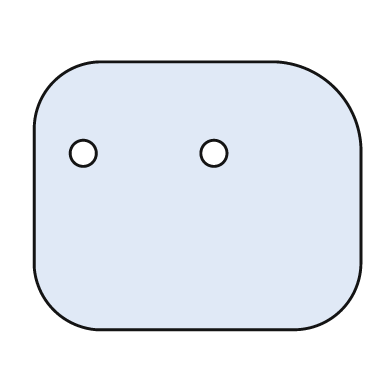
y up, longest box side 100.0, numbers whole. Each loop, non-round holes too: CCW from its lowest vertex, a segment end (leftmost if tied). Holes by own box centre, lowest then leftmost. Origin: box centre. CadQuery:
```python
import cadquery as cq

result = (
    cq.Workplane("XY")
    .moveTo(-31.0, -41.0)
    .lineTo(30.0, -41.0)
    .threePointArc((44.0, -35.0), (50.0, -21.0))
    .lineTo(50.0, 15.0)
    .threePointArc((42.0, 33.0), (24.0, 41.0))
    .lineTo(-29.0, 41.0)
    .threePointArc((-44.0, 35.0), (-50.0, 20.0))
    .lineTo(-50.0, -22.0)
    .threePointArc((-44.0, -35.0), (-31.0, -41.0))
    .close()
    .moveTo(-35.0, 13.0)
    .circle(4.0)
    .moveTo(5.0, 13.0)
    .circle(4.0)
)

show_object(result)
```